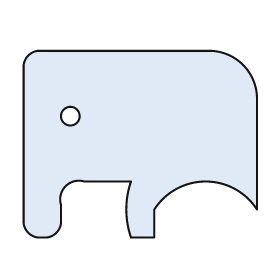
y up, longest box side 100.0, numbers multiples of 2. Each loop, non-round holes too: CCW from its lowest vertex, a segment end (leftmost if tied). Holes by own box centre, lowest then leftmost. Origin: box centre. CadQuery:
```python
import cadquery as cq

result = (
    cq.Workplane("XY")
    .moveTo(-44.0, -40.0)
    .lineTo(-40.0, -40.0)
    .threePointArc((-36.0, -38.0), (-34.0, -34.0))
    .lineTo(-34.0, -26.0)
    .threePointArc((-32.0, -18.0), (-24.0, -16.0))
    .lineTo(-4.0, -16.0)
    .threePointArc((-6.0, -28.0), (-4.0, -40.0))
    .lineTo(6.0, -40.0)
    .lineTo(6.0, -28.0)
    .threePointArc((28.0, -16.0), (50.0, -28.0))
    .lineTo(50.0, 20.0)
    .threePointArc((44.0, 34.0), (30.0, 40.0))
    .lineTo(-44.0, 40.0)
    .threePointArc((-48.0, 38.0), (-50.0, 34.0))
    .lineTo(-50.0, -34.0)
    .threePointArc((-48.0, -38.0), (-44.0, -40.0))
    .close()
    .moveTo(-30.0, 12.0)
    .circle(4.0)
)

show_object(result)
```